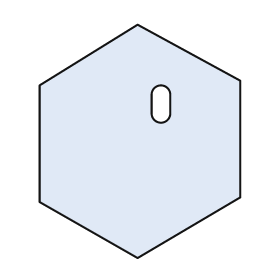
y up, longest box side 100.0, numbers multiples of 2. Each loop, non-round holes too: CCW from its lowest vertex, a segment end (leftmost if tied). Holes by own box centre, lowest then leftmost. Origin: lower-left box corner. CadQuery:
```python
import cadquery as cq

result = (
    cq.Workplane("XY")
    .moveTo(42.0, 0.0)
    .lineTo(86.0, 26.0)
    .lineTo(86.0, 76.0)
    .lineTo(42.0, 100.0)
    .lineTo(0.0, 74.0)
    .lineTo(0.0, 24.0)
    .close()
    .moveTo(48.0, 62.0)
    .threePointArc((52.0, 58.0), (56.0, 62.0))
    .lineTo(56.0, 70.0)
    .threePointArc((52.0, 74.0), (48.0, 70.0))
    .close()
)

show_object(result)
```